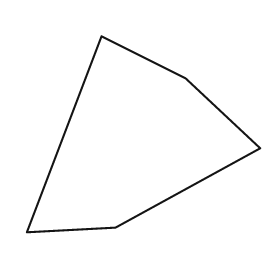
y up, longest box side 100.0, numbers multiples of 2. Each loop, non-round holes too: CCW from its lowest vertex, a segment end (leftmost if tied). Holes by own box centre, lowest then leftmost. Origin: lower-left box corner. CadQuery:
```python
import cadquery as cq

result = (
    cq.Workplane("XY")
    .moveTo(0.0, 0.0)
    .lineTo(38.0, 2.0)
    .lineTo(100.0, 36.0)
    .lineTo(68.0, 66.0)
    .lineTo(32.0, 84.0)
    .close()
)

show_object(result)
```